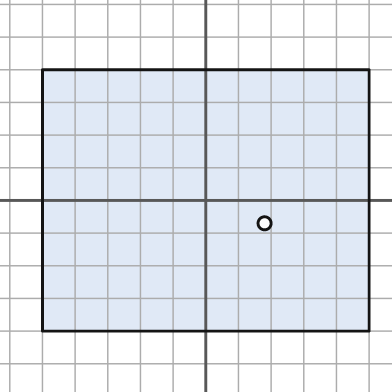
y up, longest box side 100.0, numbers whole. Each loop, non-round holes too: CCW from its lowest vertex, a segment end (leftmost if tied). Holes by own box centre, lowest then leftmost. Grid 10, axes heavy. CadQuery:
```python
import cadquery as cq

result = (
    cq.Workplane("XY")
    .moveTo(-50.0, -40.0)
    .lineTo(50.0, -40.0)
    .lineTo(50.0, 40.0)
    .lineTo(-50.0, 40.0)
    .close()
    .moveTo(18.0, -7.0)
    .circle(2.0)
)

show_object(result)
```